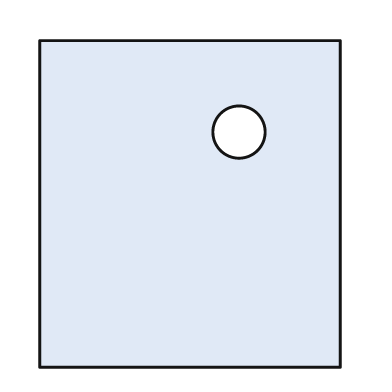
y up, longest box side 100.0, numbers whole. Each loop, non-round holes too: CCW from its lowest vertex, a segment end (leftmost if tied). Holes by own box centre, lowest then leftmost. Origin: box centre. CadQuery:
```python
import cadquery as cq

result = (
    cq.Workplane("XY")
    .moveTo(-46.0, -50.0)
    .lineTo(46.0, -50.0)
    .lineTo(46.0, 50.0)
    .lineTo(-46.0, 50.0)
    .close()
    .moveTo(15.0, 22.0)
    .circle(8.0)
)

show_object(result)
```